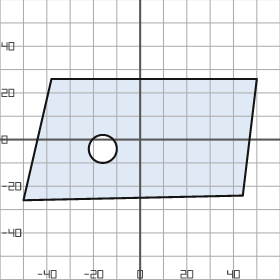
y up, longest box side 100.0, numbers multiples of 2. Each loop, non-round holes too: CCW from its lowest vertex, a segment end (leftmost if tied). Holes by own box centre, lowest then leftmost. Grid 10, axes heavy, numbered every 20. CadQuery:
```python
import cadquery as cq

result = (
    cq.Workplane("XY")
    .moveTo(-50.0, -26.0)
    .lineTo(44.0, -24.0)
    .lineTo(50.0, 26.0)
    .lineTo(-38.0, 26.0)
    .close()
    .moveTo(-16.0, -4.0)
    .circle(6.0)
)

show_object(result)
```